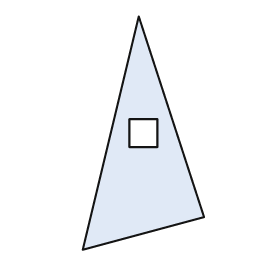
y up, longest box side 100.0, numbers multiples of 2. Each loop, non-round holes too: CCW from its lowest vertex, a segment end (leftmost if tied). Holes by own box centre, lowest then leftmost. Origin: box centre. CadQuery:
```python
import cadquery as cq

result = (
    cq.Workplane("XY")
    .moveTo(-26.0, -50.0)
    .lineTo(26.0, -36.0)
    .lineTo(-2.0, 50.0)
    .close()
    .moveTo(-6.0, -6.0)
    .lineTo(6.0, -6.0)
    .lineTo(6.0, 6.0)
    .lineTo(-6.0, 6.0)
    .close()
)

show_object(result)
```